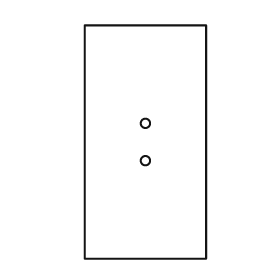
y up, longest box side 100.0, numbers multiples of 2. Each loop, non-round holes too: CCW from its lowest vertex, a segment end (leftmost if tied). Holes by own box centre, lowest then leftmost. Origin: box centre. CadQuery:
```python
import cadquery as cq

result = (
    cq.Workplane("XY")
    .moveTo(-26.0, -50.0)
    .lineTo(26.0, -50.0)
    .lineTo(26.0, 50.0)
    .lineTo(-26.0, 50.0)
    .close()
    .moveTo(0.0, -8.0)
    .circle(2.0)
    .moveTo(0.0, 8.0)
    .circle(2.0)
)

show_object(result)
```